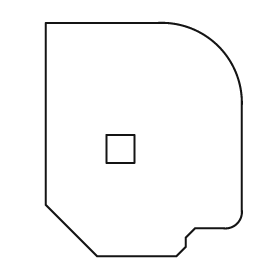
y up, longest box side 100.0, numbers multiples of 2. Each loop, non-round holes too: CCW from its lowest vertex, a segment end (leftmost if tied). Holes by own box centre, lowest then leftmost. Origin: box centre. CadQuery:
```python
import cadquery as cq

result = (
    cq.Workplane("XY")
    .moveTo(-20.0, -50.0)
    .lineTo(14.0, -50.0)
    .lineTo(18.0, -46.0)
    .lineTo(18.0, -42.0)
    .lineTo(22.0, -38.0)
    .lineTo(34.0, -38.0)
    .threePointArc((40.0, -36.0), (42.0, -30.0))
    .lineTo(42.0, 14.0)
    .threePointArc((32.0, 40.0), (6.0, 50.0))
    .lineTo(-42.0, 50.0)
    .lineTo(-42.0, -28.0)
    .close()
    .moveTo(-16.0, -10.0)
    .lineTo(-4.0, -10.0)
    .lineTo(-4.0, 2.0)
    .lineTo(-16.0, 2.0)
    .close()
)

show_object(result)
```